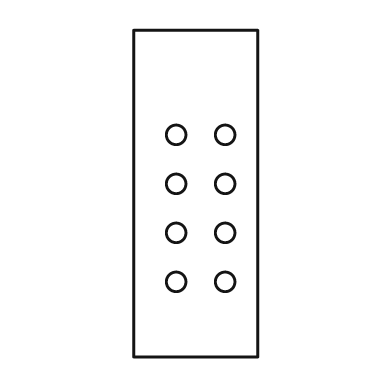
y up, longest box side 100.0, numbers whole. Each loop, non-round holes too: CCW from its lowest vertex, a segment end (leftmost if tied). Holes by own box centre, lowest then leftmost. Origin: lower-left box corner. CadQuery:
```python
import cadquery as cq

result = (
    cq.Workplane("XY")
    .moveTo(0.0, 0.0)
    .lineTo(38.0, 0.0)
    .lineTo(38.0, 100.0)
    .lineTo(0.0, 100.0)
    .close()
    .moveTo(13.0, 23.0)
    .circle(3.0)
    .moveTo(28.0, 23.0)
    .circle(3.0)
    .moveTo(13.0, 38.0)
    .circle(3.0)
    .moveTo(28.0, 38.0)
    .circle(3.0)
    .moveTo(13.0, 53.0)
    .circle(3.0)
    .moveTo(28.0, 53.0)
    .circle(3.0)
    .moveTo(13.0, 68.0)
    .circle(3.0)
    .moveTo(28.0, 68.0)
    .circle(3.0)
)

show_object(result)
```